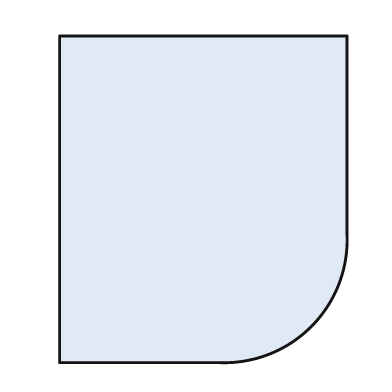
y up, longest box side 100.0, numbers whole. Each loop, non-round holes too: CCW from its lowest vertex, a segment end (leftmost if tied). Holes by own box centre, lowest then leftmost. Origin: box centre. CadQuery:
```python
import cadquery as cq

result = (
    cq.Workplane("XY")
    .moveTo(-44.0, -50.0)
    .lineTo(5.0, -50.0)
    .threePointArc((33.0, -39.0), (44.0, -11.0))
    .lineTo(44.0, 50.0)
    .lineTo(-44.0, 50.0)
    .close()
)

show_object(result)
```